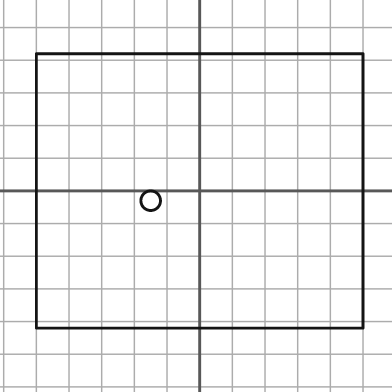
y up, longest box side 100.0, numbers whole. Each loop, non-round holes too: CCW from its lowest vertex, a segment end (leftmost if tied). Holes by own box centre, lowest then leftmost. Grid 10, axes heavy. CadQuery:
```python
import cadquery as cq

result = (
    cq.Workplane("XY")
    .moveTo(-50.0, -42.0)
    .lineTo(50.0, -42.0)
    .lineTo(50.0, 42.0)
    .lineTo(-50.0, 42.0)
    .close()
    .moveTo(-15.0, -3.0)
    .circle(3.0)
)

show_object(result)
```